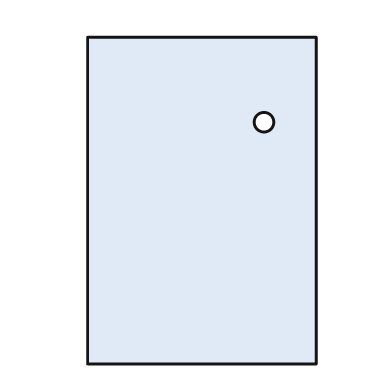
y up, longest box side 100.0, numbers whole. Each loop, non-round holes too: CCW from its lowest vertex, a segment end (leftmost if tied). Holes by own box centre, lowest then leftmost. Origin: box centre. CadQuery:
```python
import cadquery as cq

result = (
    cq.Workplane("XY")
    .moveTo(-35.0, -50.0)
    .lineTo(35.0, -50.0)
    .lineTo(35.0, 50.0)
    .lineTo(-35.0, 50.0)
    .close()
    .moveTo(19.0, 24.0)
    .circle(3.0)
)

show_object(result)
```